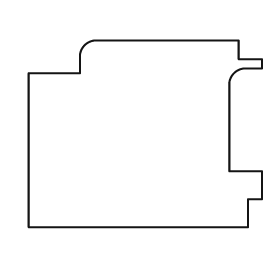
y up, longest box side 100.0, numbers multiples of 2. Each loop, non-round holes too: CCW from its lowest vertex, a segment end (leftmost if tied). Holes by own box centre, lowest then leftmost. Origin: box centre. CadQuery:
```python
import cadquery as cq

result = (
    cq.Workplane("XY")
    .moveTo(-50.0, -40.0)
    .lineTo(44.0, -40.0)
    .lineTo(44.0, -28.0)
    .lineTo(50.0, -28.0)
    .lineTo(50.0, -16.0)
    .lineTo(36.0, -16.0)
    .lineTo(36.0, 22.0)
    .threePointArc((38.0, 26.0), (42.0, 28.0))
    .lineTo(50.0, 28.0)
    .lineTo(50.0, 32.0)
    .lineTo(40.0, 32.0)
    .lineTo(40.0, 40.0)
    .lineTo(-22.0, 40.0)
    .threePointArc((-26.0, 38.0), (-28.0, 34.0))
    .lineTo(-28.0, 26.0)
    .lineTo(-50.0, 26.0)
    .close()
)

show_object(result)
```